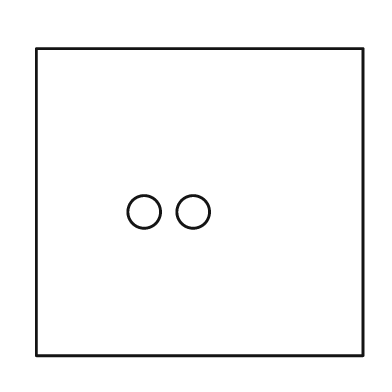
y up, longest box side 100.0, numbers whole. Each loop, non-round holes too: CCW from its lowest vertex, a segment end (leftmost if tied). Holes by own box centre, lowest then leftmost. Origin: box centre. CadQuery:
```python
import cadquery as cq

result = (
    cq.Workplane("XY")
    .moveTo(-50.0, -47.0)
    .lineTo(50.0, -47.0)
    .lineTo(50.0, 47.0)
    .lineTo(-50.0, 47.0)
    .close()
    .moveTo(-17.0, -3.0)
    .circle(5.0)
    .moveTo(-2.0, -3.0)
    .circle(5.0)
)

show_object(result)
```